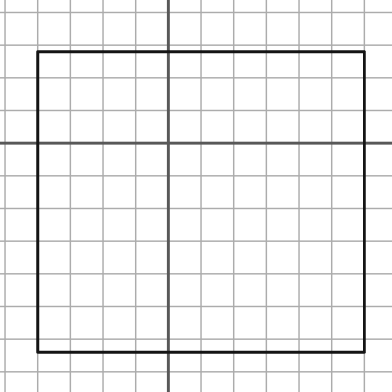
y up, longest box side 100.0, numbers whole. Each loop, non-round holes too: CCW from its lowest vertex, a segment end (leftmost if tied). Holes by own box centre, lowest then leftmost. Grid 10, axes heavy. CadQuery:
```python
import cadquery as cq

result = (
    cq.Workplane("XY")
    .moveTo(-40.0, -64.0)
    .lineTo(60.0, -64.0)
    .lineTo(60.0, 28.0)
    .lineTo(-40.0, 28.0)
    .close()
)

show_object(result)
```